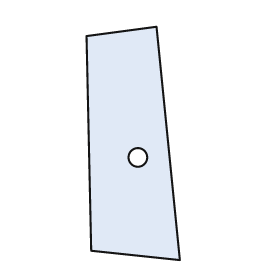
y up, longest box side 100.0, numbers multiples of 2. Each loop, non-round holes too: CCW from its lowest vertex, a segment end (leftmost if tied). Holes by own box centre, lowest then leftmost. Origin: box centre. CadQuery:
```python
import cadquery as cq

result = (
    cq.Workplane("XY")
    .moveTo(20.0, -50.0)
    .lineTo(10.0, 50.0)
    .lineTo(-20.0, 46.0)
    .lineTo(-18.0, -46.0)
    .close()
    .moveTo(2.0, -6.0)
    .circle(4.0)
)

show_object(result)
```